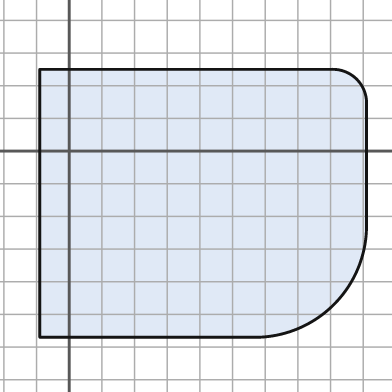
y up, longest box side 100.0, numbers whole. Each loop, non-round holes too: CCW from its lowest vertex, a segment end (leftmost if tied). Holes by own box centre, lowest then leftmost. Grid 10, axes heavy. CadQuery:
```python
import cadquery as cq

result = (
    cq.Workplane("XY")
    .moveTo(-9.0, -57.0)
    .lineTo(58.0, -57.0)
    .threePointArc((81.0, -47.0), (91.0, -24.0))
    .lineTo(91.0, 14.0)
    .threePointArc((88.0, 22.0), (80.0, 25.0))
    .lineTo(-9.0, 25.0)
    .close()
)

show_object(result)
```